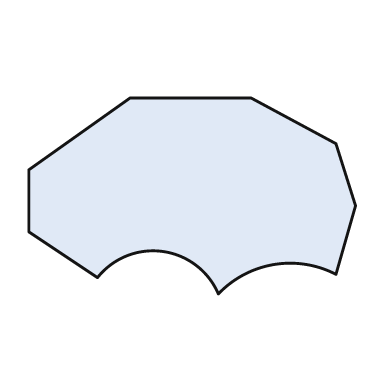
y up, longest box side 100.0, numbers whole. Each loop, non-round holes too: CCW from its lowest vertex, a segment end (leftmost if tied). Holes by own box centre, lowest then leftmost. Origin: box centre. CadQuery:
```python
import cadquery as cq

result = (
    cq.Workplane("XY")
    .moveTo(8.0, -30.0)
    .threePointArc((25.0, -21.0), (44.0, -24.0))
    .lineTo(50.0, -3.0)
    .lineTo(44.0, 16.0)
    .lineTo(18.0, 30.0)
    .lineTo(-19.0, 30.0)
    .lineTo(-50.0, 8.0)
    .lineTo(-50.0, -11.0)
    .lineTo(-29.0, -25.0)
    .threePointArc((-9.0, -17.0), (8.0, -30.0))
    .close()
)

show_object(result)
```